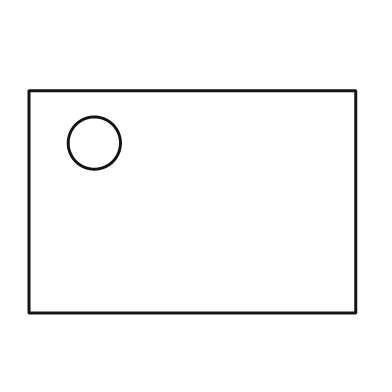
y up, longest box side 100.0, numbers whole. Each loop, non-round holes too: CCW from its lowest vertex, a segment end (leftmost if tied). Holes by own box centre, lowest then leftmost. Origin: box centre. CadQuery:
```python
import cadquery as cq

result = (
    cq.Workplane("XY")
    .moveTo(-50.0, -34.0)
    .lineTo(50.0, -34.0)
    .lineTo(50.0, 34.0)
    .lineTo(-50.0, 34.0)
    .close()
    .moveTo(-30.0, 18.0)
    .circle(8.0)
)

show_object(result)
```